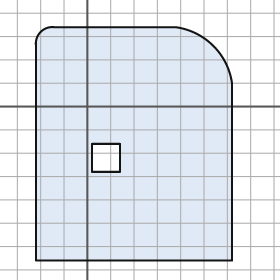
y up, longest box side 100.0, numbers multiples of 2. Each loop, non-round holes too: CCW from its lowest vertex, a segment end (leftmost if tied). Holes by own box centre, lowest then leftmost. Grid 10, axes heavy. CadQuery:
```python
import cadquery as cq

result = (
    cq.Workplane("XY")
    .moveTo(-22.0, -66.0)
    .lineTo(62.0, -66.0)
    .lineTo(62.0, 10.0)
    .threePointArc((54.0, 26.0), (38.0, 34.0))
    .lineTo(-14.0, 34.0)
    .threePointArc((-20.0, 32.0), (-22.0, 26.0))
    .close()
    .moveTo(2.0, -28.0)
    .lineTo(14.0, -28.0)
    .lineTo(14.0, -16.0)
    .lineTo(2.0, -16.0)
    .close()
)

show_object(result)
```